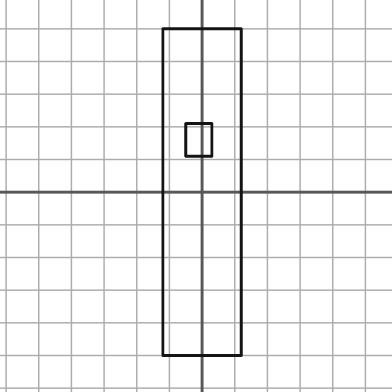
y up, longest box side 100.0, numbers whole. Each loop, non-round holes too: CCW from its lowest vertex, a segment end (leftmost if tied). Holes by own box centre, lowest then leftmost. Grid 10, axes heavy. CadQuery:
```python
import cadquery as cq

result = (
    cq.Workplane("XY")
    .moveTo(-12.0, -50.0)
    .lineTo(12.0, -50.0)
    .lineTo(12.0, 50.0)
    .lineTo(-12.0, 50.0)
    .close()
    .moveTo(-5.0, 11.0)
    .lineTo(3.0, 11.0)
    .lineTo(3.0, 21.0)
    .lineTo(-5.0, 21.0)
    .close()
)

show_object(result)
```